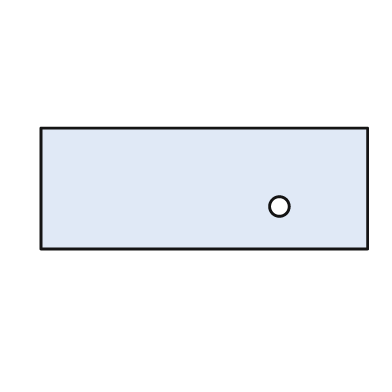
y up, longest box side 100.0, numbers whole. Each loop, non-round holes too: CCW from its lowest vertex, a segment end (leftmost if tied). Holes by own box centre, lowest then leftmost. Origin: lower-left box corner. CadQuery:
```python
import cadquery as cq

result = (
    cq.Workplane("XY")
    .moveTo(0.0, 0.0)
    .lineTo(100.0, 0.0)
    .lineTo(100.0, 37.0)
    .lineTo(0.0, 37.0)
    .close()
    .moveTo(73.0, 13.0)
    .circle(3.0)
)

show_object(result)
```